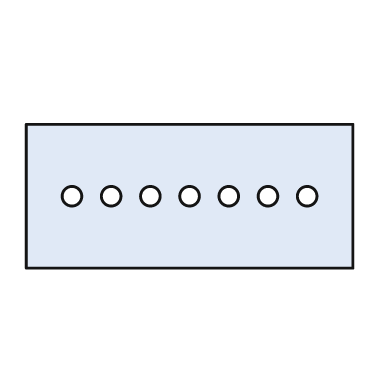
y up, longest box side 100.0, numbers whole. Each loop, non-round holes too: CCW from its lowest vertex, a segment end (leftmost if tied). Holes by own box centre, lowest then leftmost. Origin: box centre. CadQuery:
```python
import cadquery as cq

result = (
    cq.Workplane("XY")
    .moveTo(-50.0, -22.0)
    .lineTo(50.0, -22.0)
    .lineTo(50.0, 22.0)
    .lineTo(-50.0, 22.0)
    .close()
    .moveTo(-36.0, 0.0)
    .circle(3.0)
    .moveTo(-24.0, 0.0)
    .circle(3.0)
    .moveTo(-12.0, 0.0)
    .circle(3.0)
    .moveTo(0.0, 0.0)
    .circle(3.0)
    .moveTo(12.0, 0.0)
    .circle(3.0)
    .moveTo(24.0, 0.0)
    .circle(3.0)
    .moveTo(36.0, 0.0)
    .circle(3.0)
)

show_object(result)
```